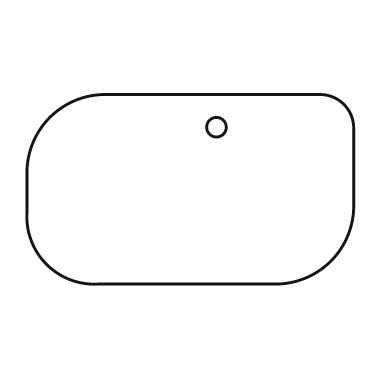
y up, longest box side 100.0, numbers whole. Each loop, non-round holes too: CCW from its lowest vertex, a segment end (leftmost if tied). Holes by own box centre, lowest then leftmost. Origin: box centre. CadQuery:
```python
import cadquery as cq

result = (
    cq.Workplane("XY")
    .moveTo(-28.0, -29.0)
    .lineTo(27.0, -29.0)
    .threePointArc((43.0, -22.0), (50.0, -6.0))
    .lineTo(50.0, 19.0)
    .threePointArc((47.0, 26.0), (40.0, 29.0))
    .lineTo(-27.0, 29.0)
    .threePointArc((-43.0, 22.0), (-50.0, 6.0))
    .lineTo(-50.0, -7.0)
    .threePointArc((-44.0, -23.0), (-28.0, -29.0))
    .close()
    .moveTo(8.0, 19.0)
    .circle(3.0)
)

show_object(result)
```